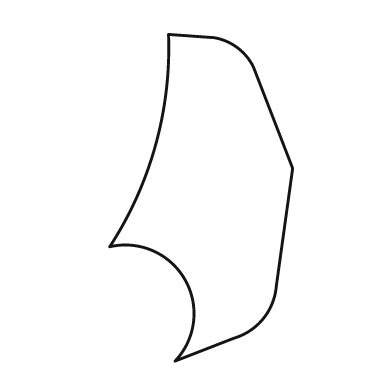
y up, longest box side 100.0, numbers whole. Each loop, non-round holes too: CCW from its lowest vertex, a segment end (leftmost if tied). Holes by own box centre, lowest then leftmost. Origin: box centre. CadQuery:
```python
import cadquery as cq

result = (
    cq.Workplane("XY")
    .moveTo(-8.0, -50.0)
    .lineTo(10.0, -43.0)
    .threePointArc((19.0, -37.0), (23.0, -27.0))
    .lineTo(28.0, 9.0)
    .lineTo(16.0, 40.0)
    .threePointArc((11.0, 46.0), (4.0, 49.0))
    .lineTo(-10.0, 50.0)
    .threePointArc((-14.0, 16.0), (-28.0, -15.0))
    .threePointArc((-5.0, -25.0), (-8.0, -50.0))
    .close()
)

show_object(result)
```